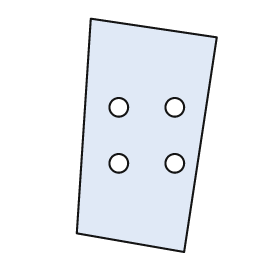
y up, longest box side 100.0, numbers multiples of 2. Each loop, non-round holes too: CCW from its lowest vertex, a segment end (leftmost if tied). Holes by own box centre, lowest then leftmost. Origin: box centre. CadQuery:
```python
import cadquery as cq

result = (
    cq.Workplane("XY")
    .moveTo(16.0, -50.0)
    .lineTo(30.0, 42.0)
    .lineTo(-24.0, 50.0)
    .lineTo(-30.0, -42.0)
    .close()
    .moveTo(-12.0, -12.0)
    .circle(4.0)
    .moveTo(12.0, -12.0)
    .circle(4.0)
    .moveTo(-12.0, 12.0)
    .circle(4.0)
    .moveTo(12.0, 12.0)
    .circle(4.0)
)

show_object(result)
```